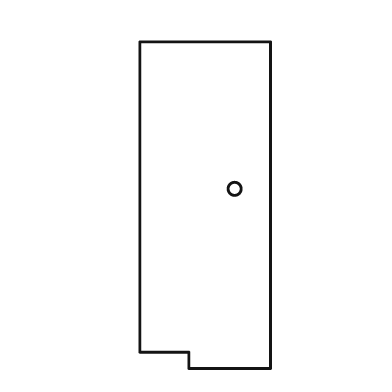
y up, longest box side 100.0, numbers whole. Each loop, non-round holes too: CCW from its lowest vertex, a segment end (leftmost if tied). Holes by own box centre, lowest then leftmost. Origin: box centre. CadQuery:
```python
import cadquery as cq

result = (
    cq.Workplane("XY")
    .moveTo(-5.0, -50.0)
    .lineTo(20.0, -50.0)
    .lineTo(20.0, 50.0)
    .lineTo(-20.0, 50.0)
    .lineTo(-20.0, -45.0)
    .lineTo(-5.0, -45.0)
    .close()
    .moveTo(9.0, 5.0)
    .circle(2.0)
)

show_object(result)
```